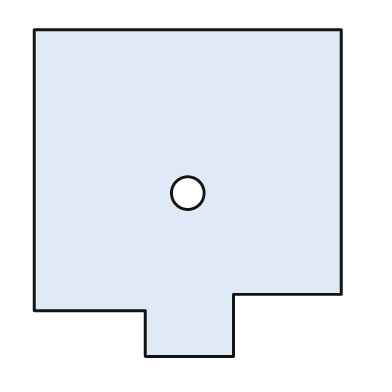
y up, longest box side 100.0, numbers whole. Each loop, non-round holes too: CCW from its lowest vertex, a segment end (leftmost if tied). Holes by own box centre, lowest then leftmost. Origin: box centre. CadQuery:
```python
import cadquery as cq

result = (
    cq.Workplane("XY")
    .moveTo(-13.0, -50.0)
    .lineTo(14.0, -50.0)
    .lineTo(14.0, -31.0)
    .lineTo(47.0, -31.0)
    .lineTo(47.0, 50.0)
    .lineTo(-47.0, 50.0)
    .lineTo(-47.0, -36.0)
    .lineTo(-13.0, -36.0)
    .close()
    .moveTo(0.0, 0.0)
    .circle(5.0)
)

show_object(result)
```